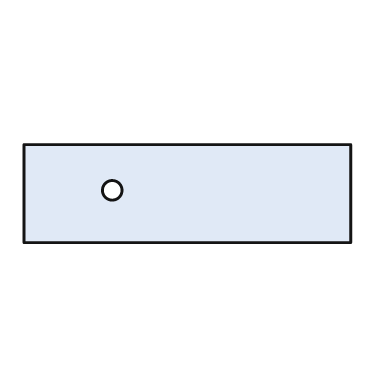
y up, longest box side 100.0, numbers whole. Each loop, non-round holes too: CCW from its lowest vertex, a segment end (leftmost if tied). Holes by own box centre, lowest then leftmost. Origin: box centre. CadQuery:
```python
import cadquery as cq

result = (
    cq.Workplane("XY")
    .moveTo(-50.0, -15.0)
    .lineTo(50.0, -15.0)
    .lineTo(50.0, 15.0)
    .lineTo(-50.0, 15.0)
    .close()
    .moveTo(-23.0, 1.0)
    .circle(3.0)
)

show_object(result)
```